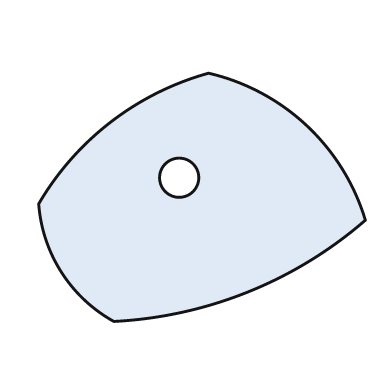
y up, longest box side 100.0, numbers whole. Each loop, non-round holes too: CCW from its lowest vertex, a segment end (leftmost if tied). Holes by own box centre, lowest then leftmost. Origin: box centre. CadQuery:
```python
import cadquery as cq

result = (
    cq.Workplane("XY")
    .moveTo(-27.0, -38.0)
    .threePointArc((14.0, -29.0), (50.0, -7.0))
    .threePointArc((32.0, 22.0), (2.0, 38.0))
    .threePointArc((-28.0, 23.0), (-50.0, -2.0))
    .threePointArc((-43.0, -23.0), (-27.0, -38.0))
    .close()
    .moveTo(-7.0, 6.0)
    .circle(6.0)
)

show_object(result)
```